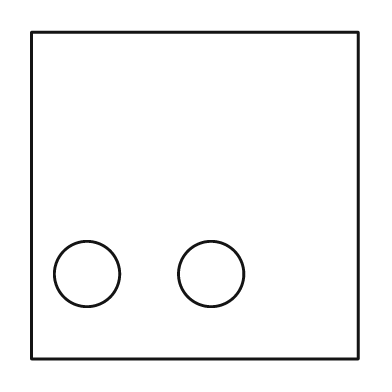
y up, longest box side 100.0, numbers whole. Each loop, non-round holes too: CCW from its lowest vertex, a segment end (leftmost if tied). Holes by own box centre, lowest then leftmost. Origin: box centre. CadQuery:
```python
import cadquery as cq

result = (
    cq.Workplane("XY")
    .moveTo(-50.0, -50.0)
    .lineTo(50.0, -50.0)
    .lineTo(50.0, 50.0)
    .lineTo(-50.0, 50.0)
    .close()
    .moveTo(-33.0, -24.0)
    .circle(10.0)
    .moveTo(5.0, -24.0)
    .circle(10.0)
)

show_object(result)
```